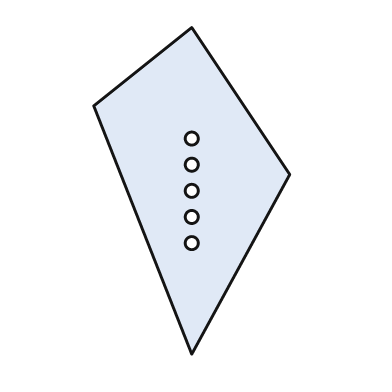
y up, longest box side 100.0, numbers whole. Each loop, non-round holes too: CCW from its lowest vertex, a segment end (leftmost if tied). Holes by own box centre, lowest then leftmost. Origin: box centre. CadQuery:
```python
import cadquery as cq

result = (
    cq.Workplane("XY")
    .moveTo(0.0, -50.0)
    .lineTo(30.0, 5.0)
    .lineTo(0.0, 50.0)
    .lineTo(-30.0, 26.0)
    .close()
    .moveTo(0.0, -16.0)
    .circle(2.0)
    .moveTo(0.0, -8.0)
    .circle(2.0)
    .moveTo(0.0, 0.0)
    .circle(2.0)
    .moveTo(0.0, 8.0)
    .circle(2.0)
    .moveTo(0.0, 16.0)
    .circle(2.0)
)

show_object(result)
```